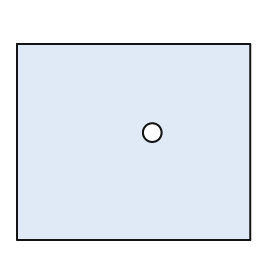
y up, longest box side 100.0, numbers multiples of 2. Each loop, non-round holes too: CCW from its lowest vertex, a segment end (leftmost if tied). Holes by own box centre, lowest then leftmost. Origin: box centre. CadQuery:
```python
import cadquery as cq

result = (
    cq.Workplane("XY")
    .moveTo(-50.0, -42.0)
    .lineTo(50.0, -42.0)
    .lineTo(50.0, 42.0)
    .lineTo(-50.0, 42.0)
    .close()
    .moveTo(8.0, 4.0)
    .circle(4.0)
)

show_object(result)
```